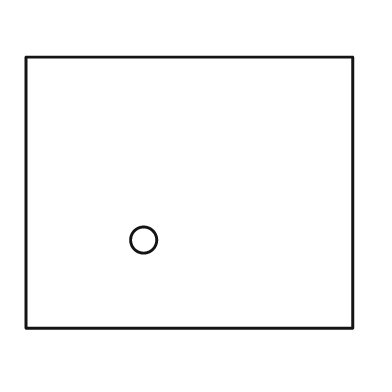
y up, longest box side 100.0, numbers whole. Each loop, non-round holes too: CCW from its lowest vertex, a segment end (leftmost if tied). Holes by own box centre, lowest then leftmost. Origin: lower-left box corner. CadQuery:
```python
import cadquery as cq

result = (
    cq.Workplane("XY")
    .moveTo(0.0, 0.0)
    .lineTo(100.0, 0.0)
    .lineTo(100.0, 83.0)
    .lineTo(0.0, 83.0)
    .close()
    .moveTo(36.0, 27.0)
    .circle(4.0)
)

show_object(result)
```